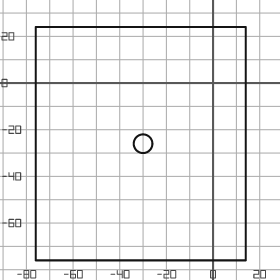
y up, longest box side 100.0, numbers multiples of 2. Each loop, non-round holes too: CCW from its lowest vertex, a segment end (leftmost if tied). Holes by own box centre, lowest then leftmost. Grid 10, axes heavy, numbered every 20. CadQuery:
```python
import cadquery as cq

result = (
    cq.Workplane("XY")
    .moveTo(-76.0, -76.0)
    .lineTo(14.0, -76.0)
    .lineTo(14.0, 24.0)
    .lineTo(-76.0, 24.0)
    .close()
    .moveTo(-30.0, -26.0)
    .circle(4.0)
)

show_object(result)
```